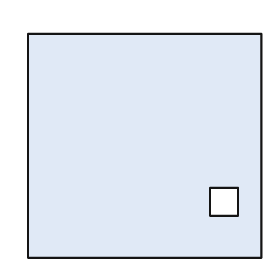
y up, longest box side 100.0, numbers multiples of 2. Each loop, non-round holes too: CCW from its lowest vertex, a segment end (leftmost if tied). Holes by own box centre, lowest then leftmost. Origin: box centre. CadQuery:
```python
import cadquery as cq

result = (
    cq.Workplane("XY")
    .moveTo(-50.0, -48.0)
    .lineTo(50.0, -48.0)
    .lineTo(50.0, 48.0)
    .lineTo(-50.0, 48.0)
    .close()
    .moveTo(28.0, -30.0)
    .lineTo(40.0, -30.0)
    .lineTo(40.0, -18.0)
    .lineTo(28.0, -18.0)
    .close()
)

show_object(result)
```